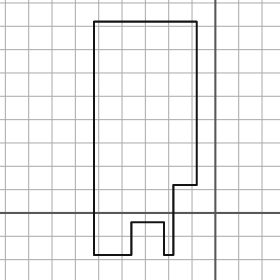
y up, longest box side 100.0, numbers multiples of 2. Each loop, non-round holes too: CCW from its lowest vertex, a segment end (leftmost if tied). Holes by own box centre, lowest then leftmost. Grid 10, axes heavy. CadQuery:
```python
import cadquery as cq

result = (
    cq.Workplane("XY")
    .moveTo(-52.0, -18.0)
    .lineTo(-36.0, -18.0)
    .lineTo(-36.0, -4.0)
    .lineTo(-22.0, -4.0)
    .lineTo(-22.0, -18.0)
    .lineTo(-18.0, -18.0)
    .lineTo(-18.0, 12.0)
    .lineTo(-8.0, 12.0)
    .lineTo(-8.0, 82.0)
    .lineTo(-52.0, 82.0)
    .close()
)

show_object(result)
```